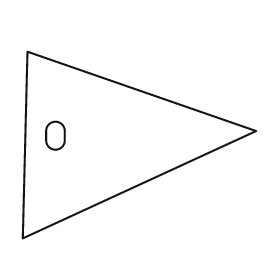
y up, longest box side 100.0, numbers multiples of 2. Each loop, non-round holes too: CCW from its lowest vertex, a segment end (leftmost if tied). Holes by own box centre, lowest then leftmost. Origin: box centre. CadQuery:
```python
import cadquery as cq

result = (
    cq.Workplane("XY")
    .moveTo(-50.0, -40.0)
    .lineTo(50.0, 6.0)
    .lineTo(-48.0, 40.0)
    .close()
    .moveTo(-40.0, 2.0)
    .threePointArc((-36.0, -2.0), (-32.0, 2.0))
    .lineTo(-32.0, 6.0)
    .threePointArc((-36.0, 10.0), (-40.0, 6.0))
    .close()
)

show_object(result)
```